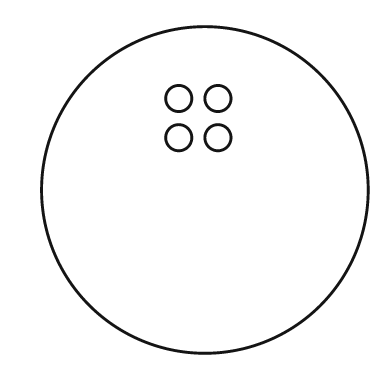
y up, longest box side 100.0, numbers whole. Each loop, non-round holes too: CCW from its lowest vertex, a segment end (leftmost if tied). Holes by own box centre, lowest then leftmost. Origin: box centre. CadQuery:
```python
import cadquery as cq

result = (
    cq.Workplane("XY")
    .moveTo(0.0, 0.0)
    .circle(50.0)
    .moveTo(-8.0, 16.0)
    .circle(4.0)
    .moveTo(4.0, 16.0)
    .circle(4.0)
    .moveTo(-8.0, 28.0)
    .circle(4.0)
    .moveTo(4.0, 28.0)
    .circle(4.0)
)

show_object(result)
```